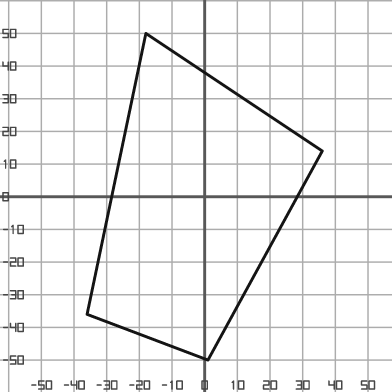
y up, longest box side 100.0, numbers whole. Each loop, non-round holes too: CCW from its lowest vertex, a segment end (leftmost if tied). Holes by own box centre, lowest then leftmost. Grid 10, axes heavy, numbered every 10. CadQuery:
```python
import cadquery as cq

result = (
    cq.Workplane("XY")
    .moveTo(1.0, -50.0)
    .lineTo(36.0, 14.0)
    .lineTo(-18.0, 50.0)
    .lineTo(-36.0, -36.0)
    .close()
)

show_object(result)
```